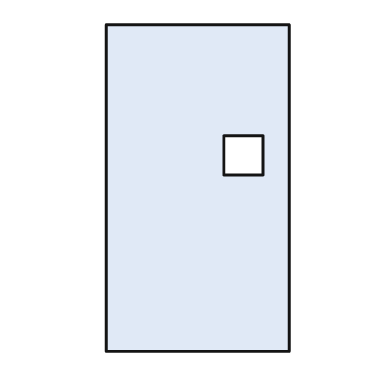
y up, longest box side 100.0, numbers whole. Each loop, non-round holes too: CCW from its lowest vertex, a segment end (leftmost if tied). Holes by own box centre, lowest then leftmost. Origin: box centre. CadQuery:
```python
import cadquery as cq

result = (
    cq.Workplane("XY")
    .moveTo(-28.0, -50.0)
    .lineTo(28.0, -50.0)
    .lineTo(28.0, 50.0)
    .lineTo(-28.0, 50.0)
    .close()
    .moveTo(8.0, 4.0)
    .lineTo(20.0, 4.0)
    .lineTo(20.0, 16.0)
    .lineTo(8.0, 16.0)
    .close()
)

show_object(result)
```